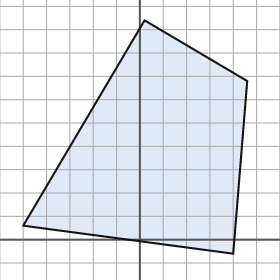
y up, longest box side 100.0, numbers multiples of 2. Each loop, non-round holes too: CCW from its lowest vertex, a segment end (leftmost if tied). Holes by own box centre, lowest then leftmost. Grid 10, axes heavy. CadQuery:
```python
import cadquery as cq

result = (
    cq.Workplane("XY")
    .moveTo(40.0, -6.0)
    .lineTo(46.0, 68.0)
    .lineTo(2.0, 94.0)
    .lineTo(-50.0, 6.0)
    .close()
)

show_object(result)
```